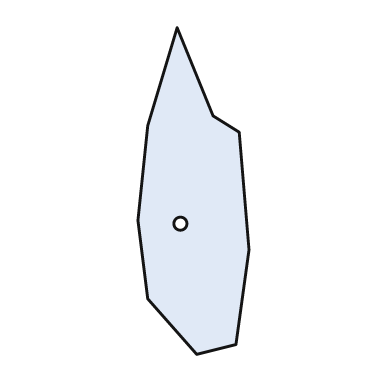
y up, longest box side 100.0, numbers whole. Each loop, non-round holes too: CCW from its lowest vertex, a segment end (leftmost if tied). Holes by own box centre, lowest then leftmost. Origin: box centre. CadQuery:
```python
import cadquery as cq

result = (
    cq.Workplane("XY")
    .moveTo(1.0, -50.0)
    .lineTo(13.0, -47.0)
    .lineTo(17.0, -18.0)
    .lineTo(14.0, 18.0)
    .lineTo(6.0, 23.0)
    .lineTo(-5.0, 50.0)
    .lineTo(-14.0, 20.0)
    .lineTo(-17.0, -9.0)
    .lineTo(-14.0, -33.0)
    .close()
    .moveTo(-4.0, -10.0)
    .circle(2.0)
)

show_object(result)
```